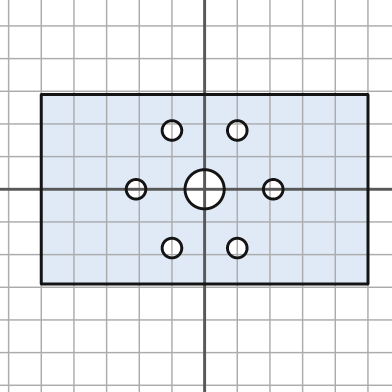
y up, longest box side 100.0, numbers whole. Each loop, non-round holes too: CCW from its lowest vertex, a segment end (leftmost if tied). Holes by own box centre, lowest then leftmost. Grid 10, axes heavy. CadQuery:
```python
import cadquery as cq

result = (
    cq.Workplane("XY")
    .moveTo(-50.0, -29.0)
    .lineTo(50.0, -29.0)
    .lineTo(50.0, 29.0)
    .lineTo(-50.0, 29.0)
    .close()
    .moveTo(-10.0, -18.0)
    .circle(3.0)
    .moveTo(10.0, -18.0)
    .circle(3.0)
    .moveTo(-21.0, 0.0)
    .circle(3.0)
    .moveTo(0.0, 0.0)
    .circle(6.0)
    .moveTo(21.0, 0.0)
    .circle(3.0)
    .moveTo(-10.0, 18.0)
    .circle(3.0)
    .moveTo(10.0, 18.0)
    .circle(3.0)
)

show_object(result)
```